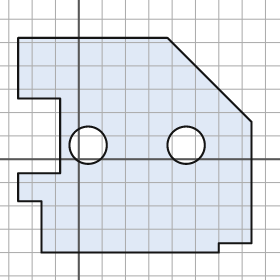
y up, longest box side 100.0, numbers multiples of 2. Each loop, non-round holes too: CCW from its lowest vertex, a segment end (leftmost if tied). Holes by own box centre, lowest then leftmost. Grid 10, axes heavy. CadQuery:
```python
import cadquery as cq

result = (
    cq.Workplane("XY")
    .moveTo(-16.0, -40.0)
    .lineTo(60.0, -40.0)
    .lineTo(60.0, -36.0)
    .lineTo(74.0, -36.0)
    .lineTo(74.0, 16.0)
    .lineTo(38.0, 52.0)
    .lineTo(-26.0, 52.0)
    .lineTo(-26.0, 26.0)
    .lineTo(-8.0, 26.0)
    .lineTo(-8.0, -6.0)
    .lineTo(-26.0, -6.0)
    .lineTo(-26.0, -18.0)
    .lineTo(-16.0, -18.0)
    .close()
    .moveTo(4.0, 6.0)
    .circle(8.0)
    .moveTo(46.0, 6.0)
    .circle(8.0)
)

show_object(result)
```